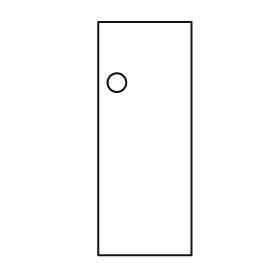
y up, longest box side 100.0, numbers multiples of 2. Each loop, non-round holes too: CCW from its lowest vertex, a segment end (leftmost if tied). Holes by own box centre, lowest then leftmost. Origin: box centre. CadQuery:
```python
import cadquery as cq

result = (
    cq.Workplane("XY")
    .moveTo(-20.0, -50.0)
    .lineTo(20.0, -50.0)
    .lineTo(20.0, 50.0)
    .lineTo(-20.0, 50.0)
    .close()
    .moveTo(-12.0, 24.0)
    .circle(4.0)
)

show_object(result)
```